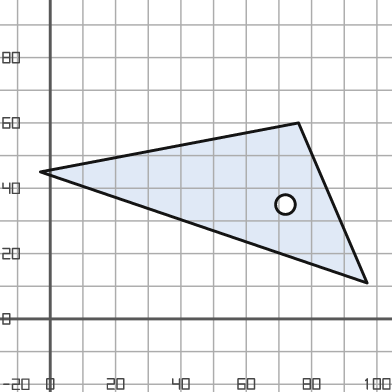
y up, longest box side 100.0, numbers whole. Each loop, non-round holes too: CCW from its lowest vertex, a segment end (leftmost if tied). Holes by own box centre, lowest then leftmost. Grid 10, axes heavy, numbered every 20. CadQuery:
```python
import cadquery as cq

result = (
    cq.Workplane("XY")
    .moveTo(97.0, 11.0)
    .lineTo(76.0, 60.0)
    .lineTo(-3.0, 45.0)
    .close()
    .moveTo(72.0, 35.0)
    .circle(3.0)
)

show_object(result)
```